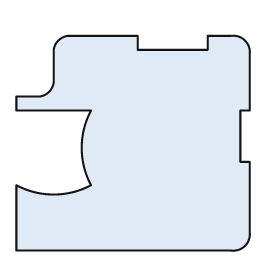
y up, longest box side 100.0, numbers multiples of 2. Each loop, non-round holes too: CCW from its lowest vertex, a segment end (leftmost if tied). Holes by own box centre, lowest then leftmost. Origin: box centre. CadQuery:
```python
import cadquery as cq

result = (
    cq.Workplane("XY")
    .moveTo(-50.0, -46.0)
    .lineTo(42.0, -46.0)
    .threePointArc((48.0, -44.0), (50.0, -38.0))
    .lineTo(50.0, -8.0)
    .lineTo(46.0, -8.0)
    .lineTo(46.0, 14.0)
    .lineTo(50.0, 14.0)
    .lineTo(50.0, 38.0)
    .threePointArc((48.0, 44.0), (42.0, 46.0))
    .lineTo(32.0, 46.0)
    .lineTo(32.0, 40.0)
    .lineTo(2.0, 40.0)
    .lineTo(2.0, 46.0)
    .lineTo(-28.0, 46.0)
    .threePointArc((-32.0, 44.0), (-34.0, 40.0))
    .lineTo(-34.0, 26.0)
    .threePointArc((-36.0, 22.0), (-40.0, 20.0))
    .lineTo(-50.0, 20.0)
    .lineTo(-50.0, 14.0)
    .lineTo(-18.0, 14.0)
    .threePointArc((-22.0, -2.0), (-18.0, -18.0))
    .threePointArc((-34.0, -22.0), (-50.0, -18.0))
    .close()
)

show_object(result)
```